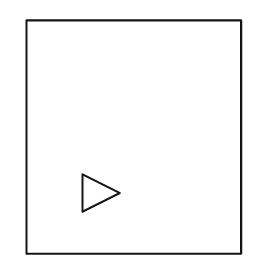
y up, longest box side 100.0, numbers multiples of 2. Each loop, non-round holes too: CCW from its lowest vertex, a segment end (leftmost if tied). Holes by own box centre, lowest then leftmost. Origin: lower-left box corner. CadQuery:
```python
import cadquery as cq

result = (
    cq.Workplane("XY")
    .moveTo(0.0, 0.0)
    .lineTo(92.0, 0.0)
    .lineTo(92.0, 100.0)
    .lineTo(0.0, 100.0)
    .close()
    .moveTo(24.0, 18.0)
    .lineTo(40.0, 26.0)
    .lineTo(24.0, 34.0)
    .close()
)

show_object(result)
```